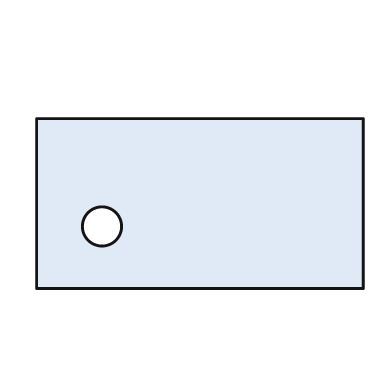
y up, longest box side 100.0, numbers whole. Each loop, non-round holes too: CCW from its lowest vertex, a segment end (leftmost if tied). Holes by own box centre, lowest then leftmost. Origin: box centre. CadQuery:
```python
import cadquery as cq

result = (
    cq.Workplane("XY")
    .moveTo(-50.0, -26.0)
    .lineTo(50.0, -26.0)
    .lineTo(50.0, 26.0)
    .lineTo(-50.0, 26.0)
    .close()
    .moveTo(-30.0, -7.0)
    .circle(6.0)
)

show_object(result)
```